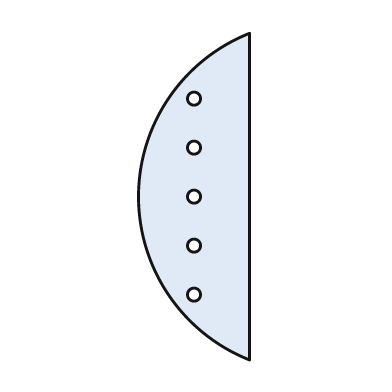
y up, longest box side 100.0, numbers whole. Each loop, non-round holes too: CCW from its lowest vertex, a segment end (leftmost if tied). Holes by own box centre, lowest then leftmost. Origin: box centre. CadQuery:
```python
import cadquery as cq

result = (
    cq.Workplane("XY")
    .moveTo(17.0, -50.0)
    .lineTo(17.0, 50.0)
    .threePointArc((-17.0, 0.0), (17.0, -50.0))
    .close()
    .moveTo(0.0, -30.0)
    .circle(2.0)
    .moveTo(0.0, -15.0)
    .circle(2.0)
    .moveTo(0.0, 0.0)
    .circle(2.0)
    .moveTo(0.0, 15.0)
    .circle(2.0)
    .moveTo(0.0, 30.0)
    .circle(2.0)
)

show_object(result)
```